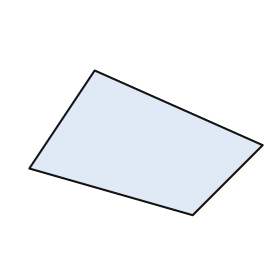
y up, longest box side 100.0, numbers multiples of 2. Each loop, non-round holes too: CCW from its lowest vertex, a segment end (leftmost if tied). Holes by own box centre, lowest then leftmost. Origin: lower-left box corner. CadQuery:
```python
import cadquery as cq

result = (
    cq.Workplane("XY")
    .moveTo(70.0, 0.0)
    .lineTo(100.0, 30.0)
    .lineTo(28.0, 62.0)
    .lineTo(0.0, 20.0)
    .close()
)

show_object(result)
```